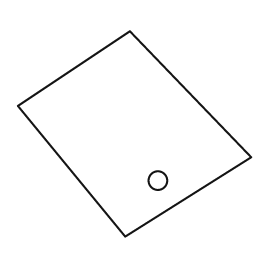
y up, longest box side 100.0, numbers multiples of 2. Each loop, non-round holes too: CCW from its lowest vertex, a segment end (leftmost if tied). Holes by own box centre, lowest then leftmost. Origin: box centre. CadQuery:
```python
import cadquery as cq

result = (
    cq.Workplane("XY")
    .moveTo(-4.0, -44.0)
    .lineTo(50.0, -10.0)
    .lineTo(-2.0, 44.0)
    .lineTo(-50.0, 12.0)
    .close()
    .moveTo(10.0, -20.0)
    .circle(4.0)
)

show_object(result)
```